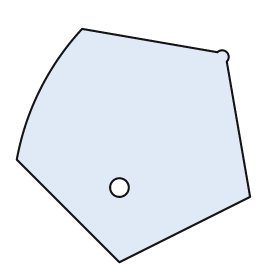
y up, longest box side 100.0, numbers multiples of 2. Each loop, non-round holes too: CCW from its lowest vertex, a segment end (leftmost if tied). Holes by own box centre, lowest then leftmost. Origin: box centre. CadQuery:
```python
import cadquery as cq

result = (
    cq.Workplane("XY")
    .moveTo(-6.0, -50.0)
    .lineTo(50.0, -22.0)
    .lineTo(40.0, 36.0)
    .threePointArc((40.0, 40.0), (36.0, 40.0))
    .lineTo(-22.0, 50.0)
    .threePointArc((-40.0, 24.0), (-50.0, -6.0))
    .close()
    .moveTo(-6.0, -18.0)
    .circle(4.0)
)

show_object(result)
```